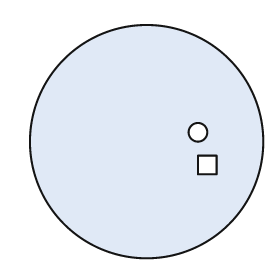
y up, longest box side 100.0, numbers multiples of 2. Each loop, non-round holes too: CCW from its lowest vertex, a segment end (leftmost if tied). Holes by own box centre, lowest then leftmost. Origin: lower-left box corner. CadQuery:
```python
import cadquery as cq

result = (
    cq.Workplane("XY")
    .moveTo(50.0, 50.0)
    .circle(50.0)
    .moveTo(72.0, 36.0)
    .lineTo(80.0, 36.0)
    .lineTo(80.0, 44.0)
    .lineTo(72.0, 44.0)
    .close()
    .moveTo(72.0, 54.0)
    .circle(4.0)
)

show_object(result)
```